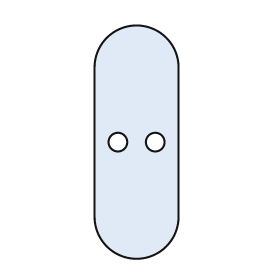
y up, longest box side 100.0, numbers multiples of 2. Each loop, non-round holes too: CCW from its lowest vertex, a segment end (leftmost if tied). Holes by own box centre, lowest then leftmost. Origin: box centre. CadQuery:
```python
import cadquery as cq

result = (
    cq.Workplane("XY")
    .moveTo(-18.0, -32.0)
    .threePointArc((0.0, -50.0), (18.0, -32.0))
    .lineTo(18.0, 32.0)
    .threePointArc((0.0, 50.0), (-18.0, 32.0))
    .close()
    .moveTo(-8.0, 0.0)
    .circle(4.0)
    .moveTo(8.0, 0.0)
    .circle(4.0)
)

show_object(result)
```